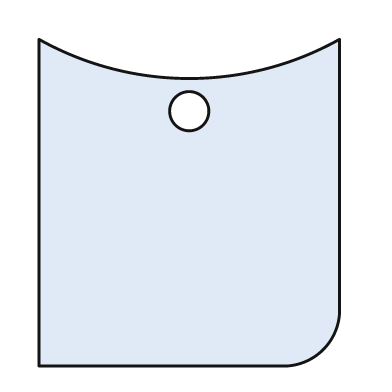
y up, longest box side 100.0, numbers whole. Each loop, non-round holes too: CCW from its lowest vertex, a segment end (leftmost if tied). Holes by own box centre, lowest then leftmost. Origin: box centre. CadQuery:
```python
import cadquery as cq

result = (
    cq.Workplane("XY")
    .moveTo(-46.0, -50.0)
    .lineTo(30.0, -50.0)
    .threePointArc((41.0, -45.0), (46.0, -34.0))
    .lineTo(46.0, 50.0)
    .threePointArc((0.0, 38.0), (-46.0, 50.0))
    .close()
    .moveTo(0.0, 28.0)
    .circle(6.0)
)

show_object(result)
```